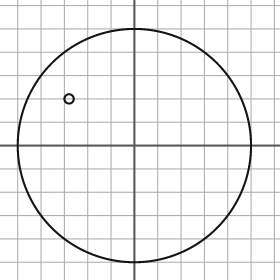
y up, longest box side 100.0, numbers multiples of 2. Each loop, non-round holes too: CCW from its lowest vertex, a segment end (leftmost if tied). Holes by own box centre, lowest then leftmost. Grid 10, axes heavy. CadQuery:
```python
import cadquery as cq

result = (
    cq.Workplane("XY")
    .moveTo(0.0, 0.0)
    .circle(50.0)
    .moveTo(-28.0, 20.0)
    .circle(2.0)
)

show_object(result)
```